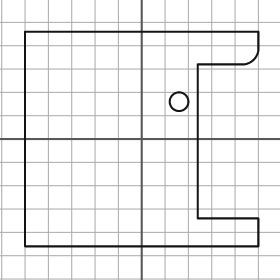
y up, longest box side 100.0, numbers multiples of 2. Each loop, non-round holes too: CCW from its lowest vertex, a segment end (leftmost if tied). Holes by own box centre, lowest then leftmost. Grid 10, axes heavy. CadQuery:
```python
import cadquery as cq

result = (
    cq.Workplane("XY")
    .moveTo(-50.0, -46.0)
    .lineTo(50.0, -46.0)
    .lineTo(50.0, -34.0)
    .lineTo(24.0, -34.0)
    .lineTo(24.0, 32.0)
    .lineTo(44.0, 32.0)
    .threePointArc((48.0, 34.0), (50.0, 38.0))
    .lineTo(50.0, 46.0)
    .lineTo(-50.0, 46.0)
    .close()
    .moveTo(16.0, 16.0)
    .circle(4.0)
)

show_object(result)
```